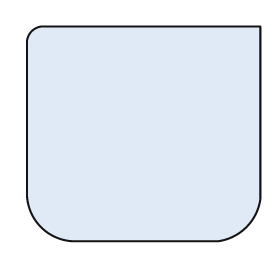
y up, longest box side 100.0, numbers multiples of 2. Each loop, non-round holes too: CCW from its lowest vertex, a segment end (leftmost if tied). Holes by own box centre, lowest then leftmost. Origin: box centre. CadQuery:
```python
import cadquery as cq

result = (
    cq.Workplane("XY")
    .moveTo(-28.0, -46.0)
    .lineTo(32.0, -46.0)
    .threePointArc((44.0, -40.0), (50.0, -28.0))
    .lineTo(50.0, 46.0)
    .lineTo(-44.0, 46.0)
    .threePointArc((-48.0, 44.0), (-50.0, 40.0))
    .lineTo(-50.0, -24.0)
    .threePointArc((-44.0, -40.0), (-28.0, -46.0))
    .close()
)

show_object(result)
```